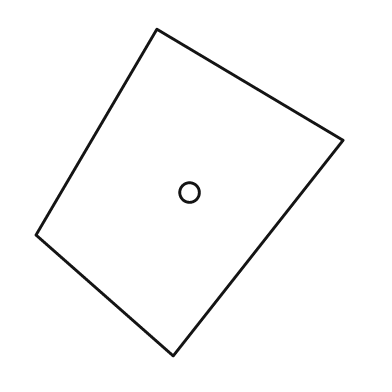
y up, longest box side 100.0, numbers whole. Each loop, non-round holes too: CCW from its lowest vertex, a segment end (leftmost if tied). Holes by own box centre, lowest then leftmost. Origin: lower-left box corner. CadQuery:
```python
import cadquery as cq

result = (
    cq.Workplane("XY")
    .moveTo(42.0, 0.0)
    .lineTo(94.0, 66.0)
    .lineTo(37.0, 100.0)
    .lineTo(0.0, 37.0)
    .close()
    .moveTo(47.0, 50.0)
    .circle(3.0)
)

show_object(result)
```